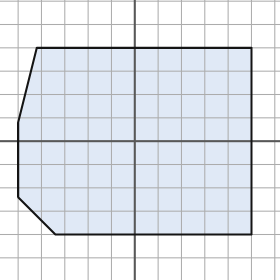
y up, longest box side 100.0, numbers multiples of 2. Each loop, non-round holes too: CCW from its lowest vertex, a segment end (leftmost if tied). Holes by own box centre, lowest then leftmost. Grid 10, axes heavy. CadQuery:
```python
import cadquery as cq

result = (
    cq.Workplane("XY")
    .moveTo(-34.0, -40.0)
    .lineTo(50.0, -40.0)
    .lineTo(50.0, 40.0)
    .lineTo(-42.0, 40.0)
    .lineTo(-50.0, 8.0)
    .lineTo(-50.0, -24.0)
    .close()
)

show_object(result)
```